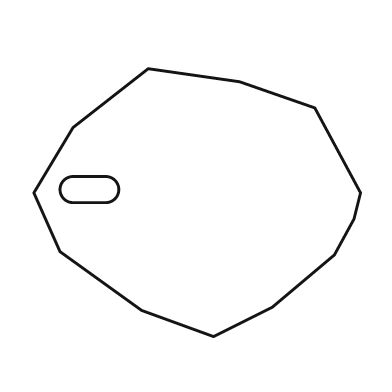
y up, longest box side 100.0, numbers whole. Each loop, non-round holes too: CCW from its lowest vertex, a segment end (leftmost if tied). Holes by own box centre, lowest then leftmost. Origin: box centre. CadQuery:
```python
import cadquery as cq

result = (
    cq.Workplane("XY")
    .moveTo(5.0, -41.0)
    .lineTo(23.0, -32.0)
    .lineTo(42.0, -16.0)
    .lineTo(48.0, -5.0)
    .lineTo(50.0, 3.0)
    .lineTo(36.0, 29.0)
    .lineTo(13.0, 37.0)
    .lineTo(-15.0, 41.0)
    .lineTo(-38.0, 23.0)
    .lineTo(-50.0, 3.0)
    .lineTo(-42.0, -15.0)
    .lineTo(-17.0, -33.0)
    .close()
    .moveTo(-38.0, 0.0)
    .lineTo(-28.0, 0.0)
    .threePointArc((-24.0, 4.0), (-28.0, 8.0))
    .lineTo(-38.0, 8.0)
    .threePointArc((-42.0, 4.0), (-38.0, 0.0))
    .close()
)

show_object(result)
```